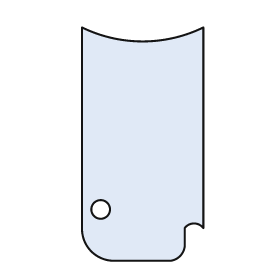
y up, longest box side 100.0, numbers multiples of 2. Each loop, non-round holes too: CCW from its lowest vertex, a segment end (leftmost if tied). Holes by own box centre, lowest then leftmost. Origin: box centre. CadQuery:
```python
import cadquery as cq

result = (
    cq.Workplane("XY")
    .moveTo(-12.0, -50.0)
    .lineTo(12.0, -50.0)
    .threePointArc((16.0, -48.0), (18.0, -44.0))
    .lineTo(18.0, -36.0)
    .threePointArc((22.0, -34.0), (26.0, -36.0))
    .lineTo(26.0, 50.0)
    .threePointArc((0.0, 44.0), (-26.0, 50.0))
    .lineTo(-26.0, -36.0)
    .threePointArc((-22.0, -46.0), (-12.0, -50.0))
    .close()
    .moveTo(-18.0, -28.0)
    .circle(4.0)
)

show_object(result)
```